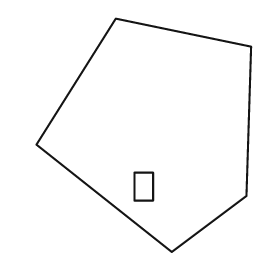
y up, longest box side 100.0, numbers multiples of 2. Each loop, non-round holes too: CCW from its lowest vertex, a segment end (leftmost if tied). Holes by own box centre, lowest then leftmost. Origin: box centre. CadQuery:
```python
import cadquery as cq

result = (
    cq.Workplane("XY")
    .moveTo(12.0, -50.0)
    .lineTo(44.0, -26.0)
    .lineTo(46.0, 38.0)
    .lineTo(-12.0, 50.0)
    .lineTo(-46.0, -4.0)
    .close()
    .moveTo(-4.0, -28.0)
    .lineTo(4.0, -28.0)
    .lineTo(4.0, -16.0)
    .lineTo(-4.0, -16.0)
    .close()
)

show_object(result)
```